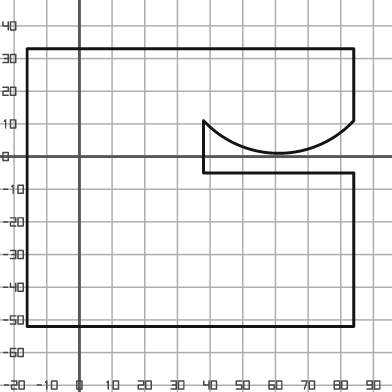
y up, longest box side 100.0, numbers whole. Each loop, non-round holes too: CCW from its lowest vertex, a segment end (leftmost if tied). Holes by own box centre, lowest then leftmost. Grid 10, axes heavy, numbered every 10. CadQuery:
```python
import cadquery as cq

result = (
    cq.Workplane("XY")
    .moveTo(-16.0, -52.0)
    .lineTo(84.0, -52.0)
    .lineTo(84.0, -5.0)
    .lineTo(38.0, -5.0)
    .lineTo(38.0, 11.0)
    .threePointArc((61.0, 1.0), (84.0, 11.0))
    .lineTo(84.0, 33.0)
    .lineTo(-16.0, 33.0)
    .close()
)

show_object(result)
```